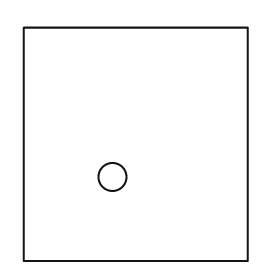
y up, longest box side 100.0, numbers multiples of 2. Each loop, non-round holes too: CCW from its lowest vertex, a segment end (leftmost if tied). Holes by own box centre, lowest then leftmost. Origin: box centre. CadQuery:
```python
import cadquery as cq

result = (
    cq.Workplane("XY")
    .moveTo(-48.0, -50.0)
    .lineTo(48.0, -50.0)
    .lineTo(48.0, 50.0)
    .lineTo(-48.0, 50.0)
    .close()
    .moveTo(-10.0, -14.0)
    .circle(6.0)
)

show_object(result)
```